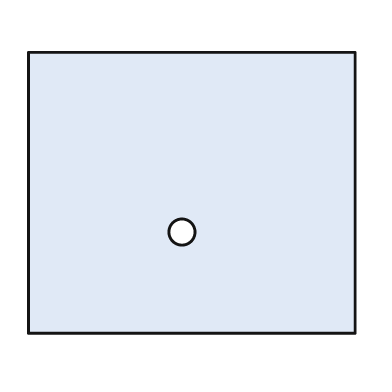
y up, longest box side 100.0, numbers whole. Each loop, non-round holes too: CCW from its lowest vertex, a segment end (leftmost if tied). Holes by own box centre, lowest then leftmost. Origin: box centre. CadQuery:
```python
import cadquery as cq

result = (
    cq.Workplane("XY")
    .moveTo(-50.0, -43.0)
    .lineTo(50.0, -43.0)
    .lineTo(50.0, 43.0)
    .lineTo(-50.0, 43.0)
    .close()
    .moveTo(-3.0, -12.0)
    .circle(4.0)
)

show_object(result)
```